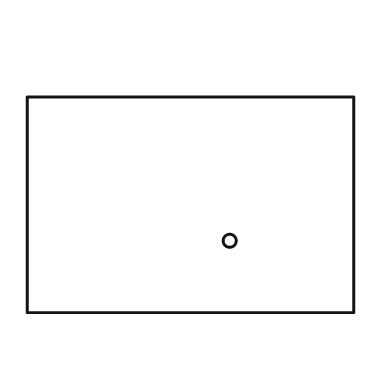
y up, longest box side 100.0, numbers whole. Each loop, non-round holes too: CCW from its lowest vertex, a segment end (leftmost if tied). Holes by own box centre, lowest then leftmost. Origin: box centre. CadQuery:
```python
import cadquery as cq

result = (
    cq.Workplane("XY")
    .moveTo(-50.0, -33.0)
    .lineTo(50.0, -33.0)
    .lineTo(50.0, 33.0)
    .lineTo(-50.0, 33.0)
    .close()
    .moveTo(12.0, -11.0)
    .circle(2.0)
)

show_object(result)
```